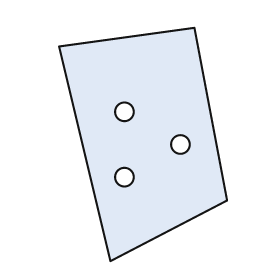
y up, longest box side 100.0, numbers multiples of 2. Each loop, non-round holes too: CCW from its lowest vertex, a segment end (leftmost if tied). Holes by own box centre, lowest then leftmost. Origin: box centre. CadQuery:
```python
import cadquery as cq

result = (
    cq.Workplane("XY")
    .moveTo(-14.0, -50.0)
    .lineTo(36.0, -24.0)
    .lineTo(22.0, 50.0)
    .lineTo(-36.0, 42.0)
    .close()
    .moveTo(-8.0, -14.0)
    .circle(4.0)
    .moveTo(16.0, 0.0)
    .circle(4.0)
    .moveTo(-8.0, 14.0)
    .circle(4.0)
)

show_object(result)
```